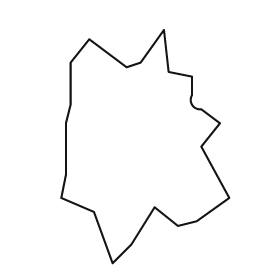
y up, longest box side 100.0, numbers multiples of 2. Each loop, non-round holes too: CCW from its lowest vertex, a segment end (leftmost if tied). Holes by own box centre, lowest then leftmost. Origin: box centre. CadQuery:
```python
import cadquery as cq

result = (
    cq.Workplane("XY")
    .moveTo(-14.0, -50.0)
    .lineTo(-6.0, -42.0)
    .lineTo(4.0, -26.0)
    .lineTo(14.0, -34.0)
    .lineTo(22.0, -32.0)
    .lineTo(36.0, -22.0)
    .lineTo(24.0, 0.0)
    .lineTo(32.0, 10.0)
    .lineTo(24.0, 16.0)
    .threePointArc((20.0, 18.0), (20.0, 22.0))
    .lineTo(20.0, 30.0)
    .lineTo(10.0, 32.0)
    .lineTo(8.0, 50.0)
    .lineTo(-2.0, 36.0)
    .lineTo(-8.0, 34.0)
    .lineTo(-24.0, 46.0)
    .lineTo(-32.0, 36.0)
    .lineTo(-32.0, 18.0)
    .lineTo(-34.0, 10.0)
    .lineTo(-34.0, -12.0)
    .lineTo(-36.0, -22.0)
    .lineTo(-22.0, -28.0)
    .close()
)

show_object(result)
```